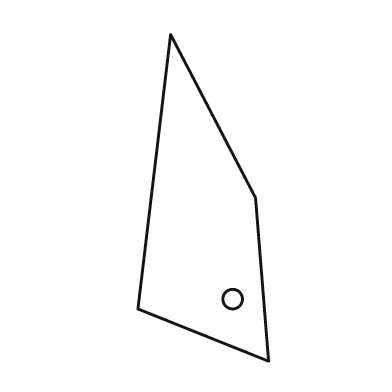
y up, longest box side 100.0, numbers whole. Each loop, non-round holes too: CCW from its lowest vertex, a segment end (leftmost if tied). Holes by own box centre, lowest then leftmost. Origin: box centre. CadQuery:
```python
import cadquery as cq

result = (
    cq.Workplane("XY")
    .moveTo(20.0, -50.0)
    .lineTo(16.0, 0.0)
    .lineTo(-10.0, 50.0)
    .lineTo(-20.0, -34.0)
    .close()
    .moveTo(9.0, -31.0)
    .circle(3.0)
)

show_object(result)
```